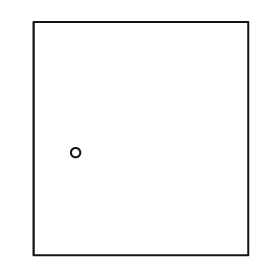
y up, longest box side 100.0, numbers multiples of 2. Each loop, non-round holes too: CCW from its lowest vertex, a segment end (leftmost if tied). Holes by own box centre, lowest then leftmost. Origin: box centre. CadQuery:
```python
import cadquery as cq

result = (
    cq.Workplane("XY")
    .moveTo(-46.0, -50.0)
    .lineTo(46.0, -50.0)
    .lineTo(46.0, 50.0)
    .lineTo(-46.0, 50.0)
    .close()
    .moveTo(-28.0, -6.0)
    .circle(2.0)
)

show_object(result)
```